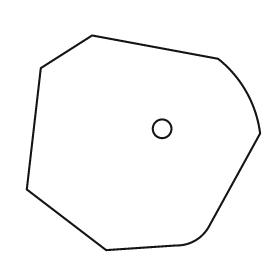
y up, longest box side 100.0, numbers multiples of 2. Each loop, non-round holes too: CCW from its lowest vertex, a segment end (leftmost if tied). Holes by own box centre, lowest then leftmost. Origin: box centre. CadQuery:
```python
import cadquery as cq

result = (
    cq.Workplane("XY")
    .moveTo(-16.0, -46.0)
    .lineTo(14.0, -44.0)
    .threePointArc((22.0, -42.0), (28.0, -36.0))
    .lineTo(50.0, 4.0)
    .threePointArc((44.0, 22.0), (32.0, 36.0))
    .lineTo(-22.0, 46.0)
    .lineTo(-44.0, 32.0)
    .lineTo(-50.0, -20.0)
    .close()
    .moveTo(8.0, 6.0)
    .circle(4.0)
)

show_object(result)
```